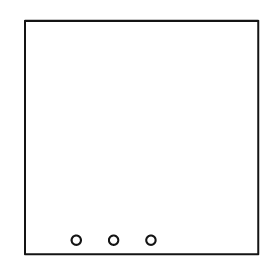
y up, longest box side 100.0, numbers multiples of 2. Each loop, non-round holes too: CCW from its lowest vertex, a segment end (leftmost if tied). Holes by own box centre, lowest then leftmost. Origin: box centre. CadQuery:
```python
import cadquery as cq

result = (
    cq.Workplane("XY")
    .moveTo(-50.0, -50.0)
    .lineTo(50.0, -50.0)
    .lineTo(50.0, 50.0)
    .lineTo(-50.0, 50.0)
    .close()
    .moveTo(-28.0, -44.0)
    .circle(2.0)
    .moveTo(-12.0, -44.0)
    .circle(2.0)
    .moveTo(4.0, -44.0)
    .circle(2.0)
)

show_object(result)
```